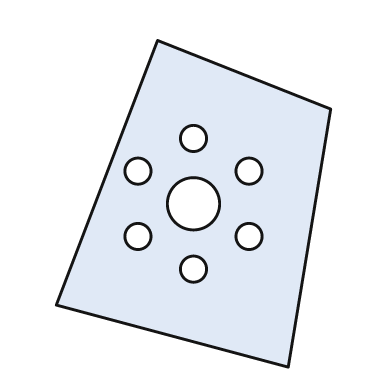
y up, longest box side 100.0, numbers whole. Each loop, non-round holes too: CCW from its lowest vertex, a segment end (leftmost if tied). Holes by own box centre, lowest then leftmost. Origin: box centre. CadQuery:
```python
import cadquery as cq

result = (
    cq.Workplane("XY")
    .moveTo(29.0, -50.0)
    .lineTo(42.0, 29.0)
    .lineTo(-11.0, 50.0)
    .lineTo(-42.0, -31.0)
    .close()
    .moveTo(0.0, -20.0)
    .circle(4.0)
    .moveTo(-17.0, -10.0)
    .circle(4.0)
    .moveTo(17.0, -10.0)
    .circle(4.0)
    .moveTo(0.0, 0.0)
    .circle(8.0)
    .moveTo(-17.0, 10.0)
    .circle(4.0)
    .moveTo(17.0, 10.0)
    .circle(4.0)
    .moveTo(0.0, 20.0)
    .circle(4.0)
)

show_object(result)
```